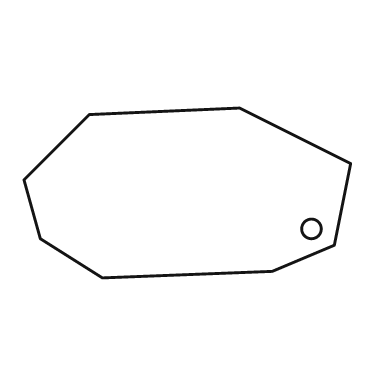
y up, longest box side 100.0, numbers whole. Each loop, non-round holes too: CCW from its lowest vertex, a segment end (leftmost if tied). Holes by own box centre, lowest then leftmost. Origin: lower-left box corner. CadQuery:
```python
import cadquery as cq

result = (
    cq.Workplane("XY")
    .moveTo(24.0, 0.0)
    .lineTo(76.0, 2.0)
    .lineTo(95.0, 10.0)
    .lineTo(100.0, 35.0)
    .lineTo(66.0, 52.0)
    .lineTo(20.0, 50.0)
    .lineTo(0.0, 30.0)
    .lineTo(5.0, 12.0)
    .close()
    .moveTo(88.0, 15.0)
    .circle(3.0)
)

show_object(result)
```